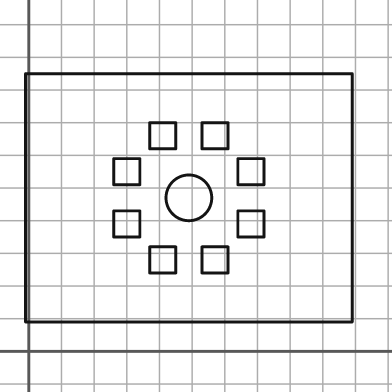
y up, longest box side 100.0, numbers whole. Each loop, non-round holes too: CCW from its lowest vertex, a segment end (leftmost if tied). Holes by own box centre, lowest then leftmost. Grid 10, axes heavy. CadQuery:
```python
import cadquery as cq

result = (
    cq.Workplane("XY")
    .moveTo(-1.0, 9.0)
    .lineTo(99.0, 9.0)
    .lineTo(99.0, 85.0)
    .lineTo(-1.0, 85.0)
    .close()
    .moveTo(37.0, 24.0)
    .lineTo(45.0, 24.0)
    .lineTo(45.0, 32.0)
    .lineTo(37.0, 32.0)
    .close()
    .moveTo(53.0, 24.0)
    .lineTo(61.0, 24.0)
    .lineTo(61.0, 32.0)
    .lineTo(53.0, 32.0)
    .close()
    .moveTo(26.0, 35.0)
    .lineTo(34.0, 35.0)
    .lineTo(34.0, 43.0)
    .lineTo(26.0, 43.0)
    .close()
    .moveTo(64.0, 35.0)
    .lineTo(72.0, 35.0)
    .lineTo(72.0, 43.0)
    .lineTo(64.0, 43.0)
    .close()
    .moveTo(49.0, 47.0)
    .circle(7.0)
    .moveTo(26.0, 51.0)
    .lineTo(34.0, 51.0)
    .lineTo(34.0, 59.0)
    .lineTo(26.0, 59.0)
    .close()
    .moveTo(64.0, 51.0)
    .lineTo(72.0, 51.0)
    .lineTo(72.0, 59.0)
    .lineTo(64.0, 59.0)
    .close()
    .moveTo(37.0, 62.0)
    .lineTo(45.0, 62.0)
    .lineTo(45.0, 70.0)
    .lineTo(37.0, 70.0)
    .close()
    .moveTo(53.0, 62.0)
    .lineTo(61.0, 62.0)
    .lineTo(61.0, 70.0)
    .lineTo(53.0, 70.0)
    .close()
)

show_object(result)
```